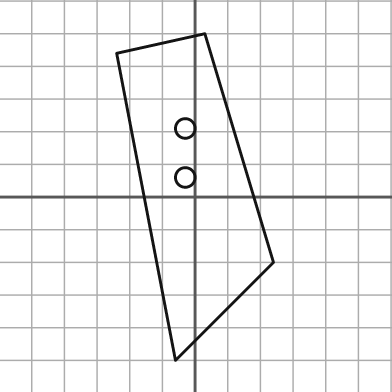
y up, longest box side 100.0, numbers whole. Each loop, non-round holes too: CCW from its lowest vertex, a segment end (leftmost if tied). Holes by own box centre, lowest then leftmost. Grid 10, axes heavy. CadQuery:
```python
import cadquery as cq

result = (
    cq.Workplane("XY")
    .moveTo(-6.0, -50.0)
    .lineTo(24.0, -20.0)
    .lineTo(3.0, 50.0)
    .lineTo(-24.0, 44.0)
    .close()
    .moveTo(-3.0, 6.0)
    .circle(3.0)
    .moveTo(-3.0, 21.0)
    .circle(3.0)
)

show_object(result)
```